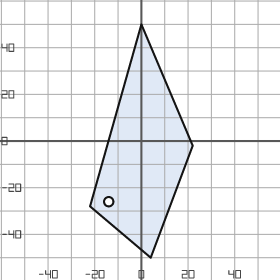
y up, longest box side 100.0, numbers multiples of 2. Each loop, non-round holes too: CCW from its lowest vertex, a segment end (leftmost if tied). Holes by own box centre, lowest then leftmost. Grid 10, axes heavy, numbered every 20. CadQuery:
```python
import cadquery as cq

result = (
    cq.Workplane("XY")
    .moveTo(4.0, -50.0)
    .lineTo(22.0, -2.0)
    .lineTo(0.0, 50.0)
    .lineTo(-22.0, -28.0)
    .close()
    .moveTo(-14.0, -26.0)
    .circle(2.0)
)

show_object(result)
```